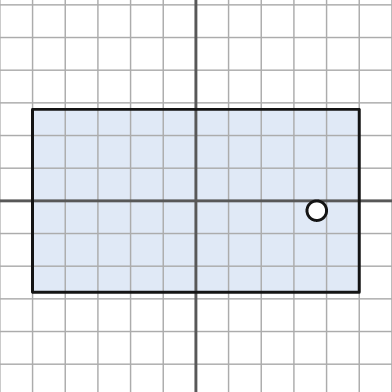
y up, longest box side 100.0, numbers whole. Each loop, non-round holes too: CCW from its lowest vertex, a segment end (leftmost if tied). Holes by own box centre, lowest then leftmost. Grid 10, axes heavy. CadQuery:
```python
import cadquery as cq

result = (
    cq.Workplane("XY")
    .moveTo(-50.0, -28.0)
    .lineTo(50.0, -28.0)
    .lineTo(50.0, 28.0)
    .lineTo(-50.0, 28.0)
    .close()
    .moveTo(37.0, -3.0)
    .circle(3.0)
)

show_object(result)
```